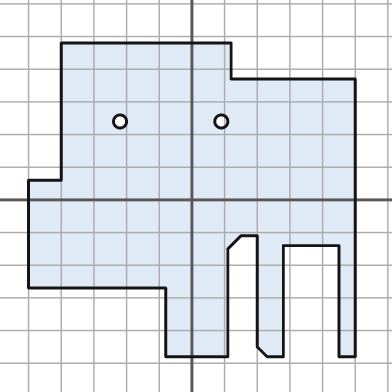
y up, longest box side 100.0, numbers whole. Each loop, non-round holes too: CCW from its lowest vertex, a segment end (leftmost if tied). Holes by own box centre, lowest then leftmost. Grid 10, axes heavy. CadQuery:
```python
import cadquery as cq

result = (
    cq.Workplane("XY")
    .moveTo(-8.0, -48.0)
    .lineTo(11.0, -48.0)
    .lineTo(11.0, -15.0)
    .lineTo(15.0, -11.0)
    .lineTo(20.0, -11.0)
    .lineTo(20.0, -45.0)
    .lineTo(23.0, -48.0)
    .lineTo(28.0, -48.0)
    .lineTo(28.0, -14.0)
    .lineTo(45.0, -14.0)
    .lineTo(45.0, -48.0)
    .lineTo(50.0, -48.0)
    .lineTo(50.0, 37.0)
    .lineTo(12.0, 37.0)
    .lineTo(12.0, 48.0)
    .lineTo(-40.0, 48.0)
    .lineTo(-40.0, 6.0)
    .lineTo(-50.0, 6.0)
    .lineTo(-50.0, -27.0)
    .lineTo(-8.0, -27.0)
    .close()
    .moveTo(-22.0, 24.0)
    .circle(2.0)
    .moveTo(9.0, 24.0)
    .circle(2.0)
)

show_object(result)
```